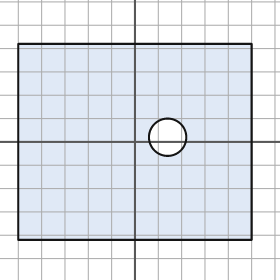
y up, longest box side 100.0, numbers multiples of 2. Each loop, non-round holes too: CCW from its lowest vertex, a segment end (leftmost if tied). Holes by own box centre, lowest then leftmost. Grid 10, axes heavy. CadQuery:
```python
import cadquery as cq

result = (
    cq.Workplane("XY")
    .moveTo(-50.0, -42.0)
    .lineTo(50.0, -42.0)
    .lineTo(50.0, 42.0)
    .lineTo(-50.0, 42.0)
    .close()
    .moveTo(14.0, 2.0)
    .circle(8.0)
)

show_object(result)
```